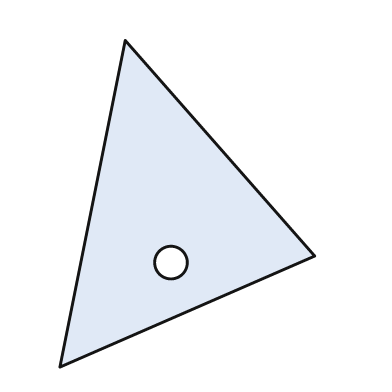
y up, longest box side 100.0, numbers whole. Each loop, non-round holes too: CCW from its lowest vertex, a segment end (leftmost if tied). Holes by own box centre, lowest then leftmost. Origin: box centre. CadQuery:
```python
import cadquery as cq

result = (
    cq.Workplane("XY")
    .moveTo(-39.0, -50.0)
    .lineTo(39.0, -16.0)
    .lineTo(-19.0, 50.0)
    .close()
    .moveTo(-5.0, -18.0)
    .circle(5.0)
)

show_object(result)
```